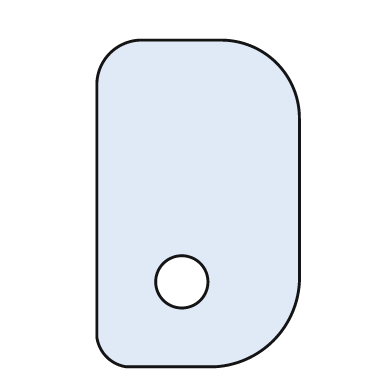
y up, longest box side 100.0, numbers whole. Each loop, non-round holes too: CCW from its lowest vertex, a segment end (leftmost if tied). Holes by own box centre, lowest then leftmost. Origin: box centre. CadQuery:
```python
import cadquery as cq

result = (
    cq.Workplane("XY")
    .moveTo(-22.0, -50.0)
    .lineTo(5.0, -50.0)
    .threePointArc((23.0, -42.0), (31.0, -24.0))
    .lineTo(31.0, 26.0)
    .threePointArc((24.0, 43.0), (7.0, 50.0))
    .lineTo(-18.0, 50.0)
    .threePointArc((-27.0, 46.0), (-31.0, 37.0))
    .lineTo(-31.0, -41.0)
    .threePointArc((-28.0, -47.0), (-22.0, -50.0))
    .close()
    .moveTo(-5.0, -24.0)
    .circle(8.0)
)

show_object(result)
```